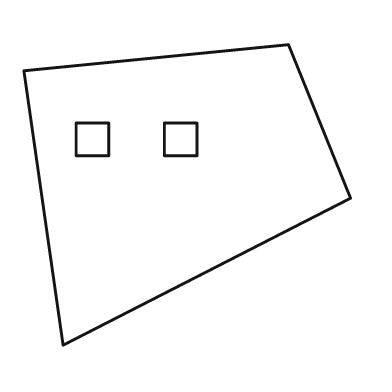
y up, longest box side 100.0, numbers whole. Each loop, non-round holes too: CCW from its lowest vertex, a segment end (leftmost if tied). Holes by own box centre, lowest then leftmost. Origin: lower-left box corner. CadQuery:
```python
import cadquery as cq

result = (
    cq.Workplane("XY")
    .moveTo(12.0, 0.0)
    .lineTo(100.0, 45.0)
    .lineTo(81.0, 92.0)
    .lineTo(0.0, 84.0)
    .close()
    .moveTo(16.0, 58.0)
    .lineTo(26.0, 58.0)
    .lineTo(26.0, 68.0)
    .lineTo(16.0, 68.0)
    .close()
    .moveTo(43.0, 58.0)
    .lineTo(53.0, 58.0)
    .lineTo(53.0, 68.0)
    .lineTo(43.0, 68.0)
    .close()
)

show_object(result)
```